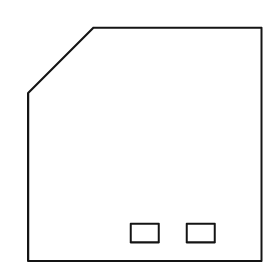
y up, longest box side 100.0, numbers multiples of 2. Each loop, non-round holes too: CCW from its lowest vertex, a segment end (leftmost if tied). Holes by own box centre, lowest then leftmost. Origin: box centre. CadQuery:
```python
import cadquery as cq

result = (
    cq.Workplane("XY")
    .moveTo(-50.0, -50.0)
    .lineTo(50.0, -50.0)
    .lineTo(50.0, 50.0)
    .lineTo(-22.0, 50.0)
    .lineTo(-50.0, 22.0)
    .close()
    .moveTo(-6.0, -42.0)
    .lineTo(6.0, -42.0)
    .lineTo(6.0, -34.0)
    .lineTo(-6.0, -34.0)
    .close()
    .moveTo(18.0, -42.0)
    .lineTo(30.0, -42.0)
    .lineTo(30.0, -34.0)
    .lineTo(18.0, -34.0)
    .close()
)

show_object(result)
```